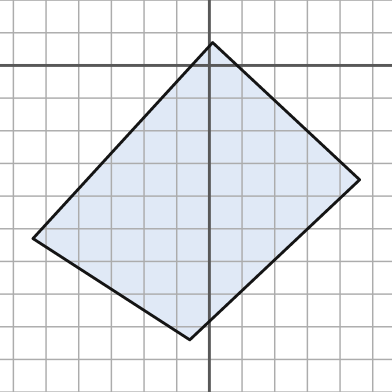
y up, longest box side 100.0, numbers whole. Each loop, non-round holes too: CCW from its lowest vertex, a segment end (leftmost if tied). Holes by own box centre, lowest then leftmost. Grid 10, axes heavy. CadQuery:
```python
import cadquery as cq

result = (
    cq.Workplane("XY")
    .moveTo(-6.0, -84.0)
    .lineTo(46.0, -35.0)
    .lineTo(1.0, 7.0)
    .lineTo(-54.0, -53.0)
    .close()
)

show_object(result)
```